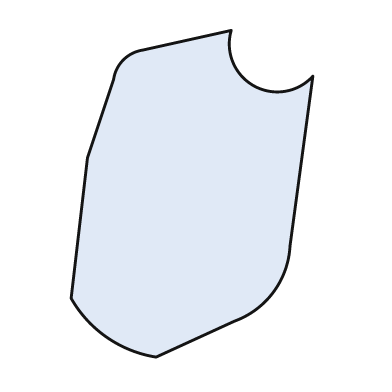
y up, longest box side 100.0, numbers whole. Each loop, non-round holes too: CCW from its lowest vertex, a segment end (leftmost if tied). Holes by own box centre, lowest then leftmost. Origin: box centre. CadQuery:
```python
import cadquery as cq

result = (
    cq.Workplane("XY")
    .moveTo(-11.0, -50.0)
    .lineTo(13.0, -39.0)
    .threePointArc((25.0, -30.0), (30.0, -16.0))
    .lineTo(37.0, 36.0)
    .threePointArc((19.0, 33.0), (12.0, 50.0))
    .lineTo(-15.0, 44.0)
    .threePointArc((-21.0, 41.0), (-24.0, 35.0))
    .lineTo(-32.0, 11.0)
    .lineTo(-37.0, -32.0)
    .threePointArc((-26.0, -44.0), (-11.0, -50.0))
    .close()
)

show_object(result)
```